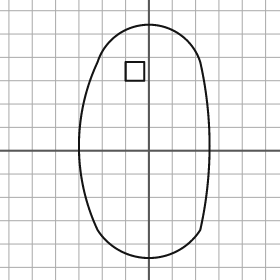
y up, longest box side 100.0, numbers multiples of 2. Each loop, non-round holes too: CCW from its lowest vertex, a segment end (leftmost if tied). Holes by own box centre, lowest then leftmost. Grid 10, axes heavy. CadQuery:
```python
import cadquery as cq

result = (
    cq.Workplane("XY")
    .moveTo(-22.0, -34.0)
    .threePointArc((0.0, -46.0), (22.0, -34.0))
    .threePointArc((26.0, 2.0), (22.0, 38.0))
    .threePointArc((0.0, 54.0), (-22.0, 38.0))
    .threePointArc((-30.0, 2.0), (-22.0, -34.0))
    .close()
    .moveTo(-10.0, 30.0)
    .lineTo(-2.0, 30.0)
    .lineTo(-2.0, 38.0)
    .lineTo(-10.0, 38.0)
    .close()
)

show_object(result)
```